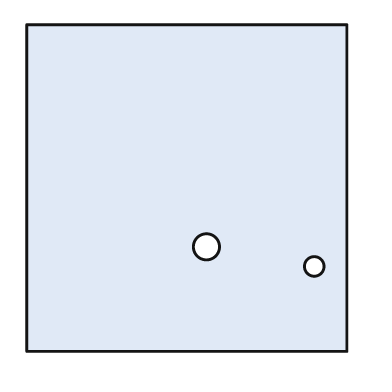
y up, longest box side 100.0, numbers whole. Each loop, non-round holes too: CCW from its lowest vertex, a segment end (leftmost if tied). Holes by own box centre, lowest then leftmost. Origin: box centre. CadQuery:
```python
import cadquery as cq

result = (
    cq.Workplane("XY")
    .moveTo(-49.0, -50.0)
    .lineTo(49.0, -50.0)
    .lineTo(49.0, 50.0)
    .lineTo(-49.0, 50.0)
    .close()
    .moveTo(39.0, -24.0)
    .circle(3.0)
    .moveTo(6.0, -18.0)
    .circle(4.0)
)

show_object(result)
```